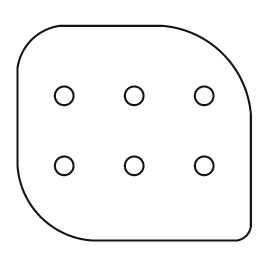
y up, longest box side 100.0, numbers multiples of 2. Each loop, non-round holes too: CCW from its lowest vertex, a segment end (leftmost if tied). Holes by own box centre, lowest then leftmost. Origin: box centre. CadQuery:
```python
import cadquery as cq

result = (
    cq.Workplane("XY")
    .moveTo(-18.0, -46.0)
    .lineTo(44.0, -46.0)
    .threePointArc((48.0, -44.0), (50.0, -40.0))
    .lineTo(50.0, 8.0)
    .threePointArc((38.0, 34.0), (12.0, 46.0))
    .lineTo(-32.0, 46.0)
    .threePointArc((-44.0, 40.0), (-50.0, 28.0))
    .lineTo(-50.0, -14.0)
    .threePointArc((-40.0, -36.0), (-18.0, -46.0))
    .close()
    .moveTo(-30.0, -14.0)
    .circle(4.0)
    .moveTo(0.0, -14.0)
    .circle(4.0)
    .moveTo(30.0, -14.0)
    .circle(4.0)
    .moveTo(-30.0, 16.0)
    .circle(4.0)
    .moveTo(0.0, 16.0)
    .circle(4.0)
    .moveTo(30.0, 16.0)
    .circle(4.0)
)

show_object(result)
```